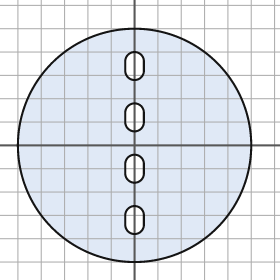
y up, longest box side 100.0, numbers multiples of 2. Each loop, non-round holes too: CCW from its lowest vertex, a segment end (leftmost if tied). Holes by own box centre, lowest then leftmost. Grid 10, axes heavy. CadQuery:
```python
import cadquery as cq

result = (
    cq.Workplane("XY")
    .moveTo(0.0, 0.0)
    .circle(50.0)
    .moveTo(-4.0, -34.0)
    .threePointArc((0.0, -38.0), (4.0, -34.0))
    .lineTo(4.0, -30.0)
    .threePointArc((0.0, -26.0), (-4.0, -30.0))
    .close()
    .moveTo(-4.0, -12.0)
    .threePointArc((0.0, -16.0), (4.0, -12.0))
    .lineTo(4.0, -8.0)
    .threePointArc((0.0, -4.0), (-4.0, -8.0))
    .close()
    .moveTo(-4.0, 10.0)
    .threePointArc((0.0, 6.0), (4.0, 10.0))
    .lineTo(4.0, 14.0)
    .threePointArc((0.0, 18.0), (-4.0, 14.0))
    .close()
    .moveTo(-4.0, 32.0)
    .threePointArc((0.0, 28.0), (4.0, 32.0))
    .lineTo(4.0, 36.0)
    .threePointArc((0.0, 40.0), (-4.0, 36.0))
    .close()
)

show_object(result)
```